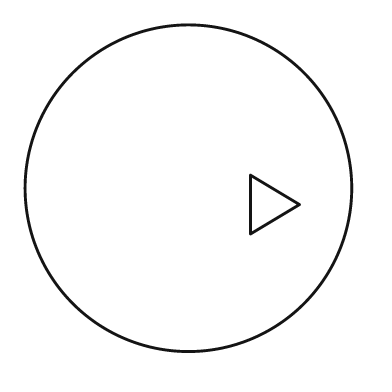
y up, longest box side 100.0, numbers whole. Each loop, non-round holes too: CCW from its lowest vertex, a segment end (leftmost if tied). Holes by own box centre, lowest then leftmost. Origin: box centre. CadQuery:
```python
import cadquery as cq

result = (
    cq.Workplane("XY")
    .moveTo(0.0, 0.0)
    .circle(50.0)
    .moveTo(19.0, -14.0)
    .lineTo(34.0, -5.0)
    .lineTo(19.0, 4.0)
    .close()
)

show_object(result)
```